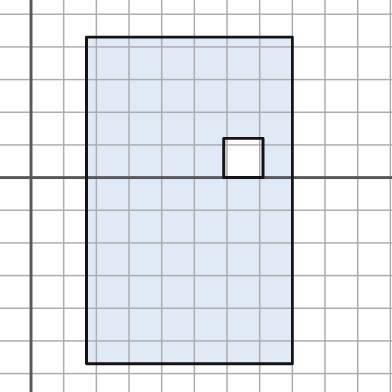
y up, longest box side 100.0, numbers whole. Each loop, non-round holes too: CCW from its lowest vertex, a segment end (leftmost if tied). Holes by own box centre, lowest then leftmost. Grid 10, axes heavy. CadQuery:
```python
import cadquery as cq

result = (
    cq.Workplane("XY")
    .moveTo(17.0, -57.0)
    .lineTo(80.0, -57.0)
    .lineTo(80.0, 43.0)
    .lineTo(17.0, 43.0)
    .close()
    .moveTo(59.0, 0.0)
    .lineTo(71.0, 0.0)
    .lineTo(71.0, 12.0)
    .lineTo(59.0, 12.0)
    .close()
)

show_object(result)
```